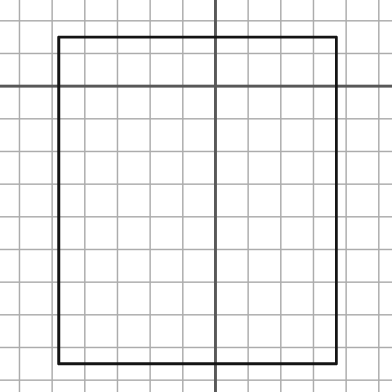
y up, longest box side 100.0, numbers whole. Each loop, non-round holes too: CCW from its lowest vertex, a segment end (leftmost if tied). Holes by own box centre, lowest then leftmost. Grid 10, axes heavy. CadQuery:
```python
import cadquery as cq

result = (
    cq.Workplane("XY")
    .moveTo(-48.0, -85.0)
    .lineTo(37.0, -85.0)
    .lineTo(37.0, 15.0)
    .lineTo(-48.0, 15.0)
    .close()
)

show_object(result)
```